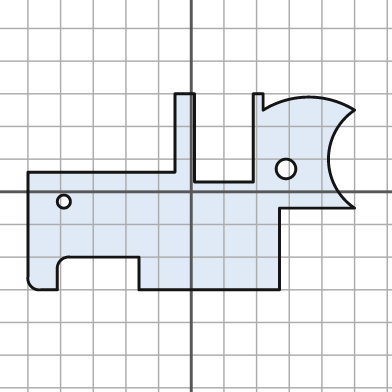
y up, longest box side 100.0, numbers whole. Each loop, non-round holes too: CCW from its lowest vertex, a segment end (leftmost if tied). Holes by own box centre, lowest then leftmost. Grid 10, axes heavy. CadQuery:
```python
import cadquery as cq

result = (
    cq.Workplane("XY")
    .moveTo(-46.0, -30.0)
    .lineTo(-41.0, -30.0)
    .lineTo(-41.0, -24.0)
    .threePointArc((-40.0, -21.0), (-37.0, -20.0))
    .lineTo(-16.0, -20.0)
    .lineTo(-16.0, -30.0)
    .lineTo(27.0, -30.0)
    .lineTo(27.0, -5.0)
    .lineTo(50.0, -5.0)
    .threePointArc((42.0, 10.0), (50.0, 25.0))
    .threePointArc((36.0, 29.0), (22.0, 25.0))
    .lineTo(22.0, 30.0)
    .lineTo(19.0, 30.0)
    .lineTo(19.0, 3.0)
    .lineTo(1.0, 3.0)
    .lineTo(1.0, 30.0)
    .lineTo(-5.0, 30.0)
    .lineTo(-5.0, 6.0)
    .lineTo(-50.0, 6.0)
    .lineTo(-50.0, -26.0)
    .threePointArc((-49.0, -29.0), (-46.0, -30.0))
    .close()
    .moveTo(-39.0, -3.0)
    .circle(2.0)
    .moveTo(29.0, 7.0)
    .circle(3.0)
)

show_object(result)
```